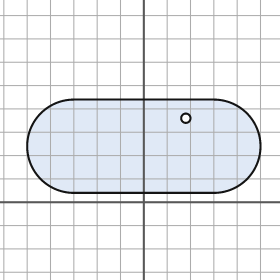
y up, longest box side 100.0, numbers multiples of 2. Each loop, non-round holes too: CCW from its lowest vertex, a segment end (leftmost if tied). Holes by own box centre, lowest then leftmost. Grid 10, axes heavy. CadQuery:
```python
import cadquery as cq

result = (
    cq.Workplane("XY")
    .moveTo(-30.0, 4.0)
    .lineTo(30.0, 4.0)
    .threePointArc((50.0, 24.0), (30.0, 44.0))
    .lineTo(-30.0, 44.0)
    .threePointArc((-50.0, 24.0), (-30.0, 4.0))
    .close()
    .moveTo(18.0, 36.0)
    .circle(2.0)
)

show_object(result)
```